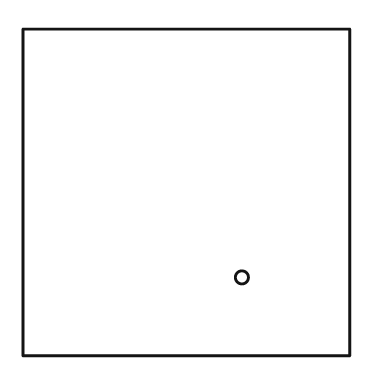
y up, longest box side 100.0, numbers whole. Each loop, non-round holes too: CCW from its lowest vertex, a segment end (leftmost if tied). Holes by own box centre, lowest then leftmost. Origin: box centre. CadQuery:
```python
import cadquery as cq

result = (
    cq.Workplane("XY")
    .moveTo(-50.0, -50.0)
    .lineTo(50.0, -50.0)
    .lineTo(50.0, 50.0)
    .lineTo(-50.0, 50.0)
    .close()
    .moveTo(17.0, -26.0)
    .circle(2.0)
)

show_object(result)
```